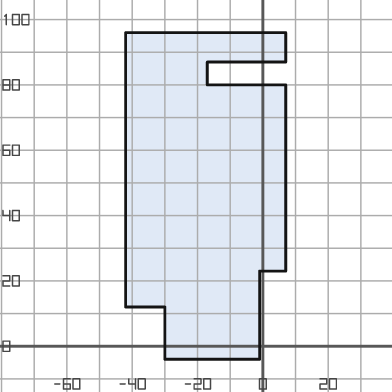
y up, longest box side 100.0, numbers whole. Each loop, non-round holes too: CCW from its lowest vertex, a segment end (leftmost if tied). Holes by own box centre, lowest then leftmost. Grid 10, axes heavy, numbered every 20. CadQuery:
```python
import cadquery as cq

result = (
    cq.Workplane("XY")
    .moveTo(-30.0, -4.0)
    .lineTo(-1.0, -4.0)
    .lineTo(-1.0, 23.0)
    .lineTo(7.0, 23.0)
    .lineTo(7.0, 80.0)
    .lineTo(-17.0, 80.0)
    .lineTo(-17.0, 87.0)
    .lineTo(7.0, 87.0)
    .lineTo(7.0, 96.0)
    .lineTo(-42.0, 96.0)
    .lineTo(-42.0, 12.0)
    .lineTo(-30.0, 12.0)
    .close()
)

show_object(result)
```